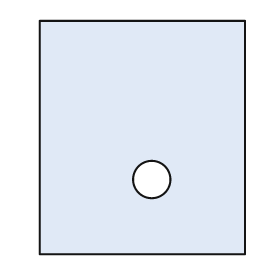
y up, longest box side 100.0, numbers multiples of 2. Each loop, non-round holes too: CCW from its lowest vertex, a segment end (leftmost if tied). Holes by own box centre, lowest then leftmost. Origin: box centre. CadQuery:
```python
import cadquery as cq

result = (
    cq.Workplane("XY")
    .moveTo(-44.0, -50.0)
    .lineTo(44.0, -50.0)
    .lineTo(44.0, 50.0)
    .lineTo(-44.0, 50.0)
    .close()
    .moveTo(4.0, -18.0)
    .circle(8.0)
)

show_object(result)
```